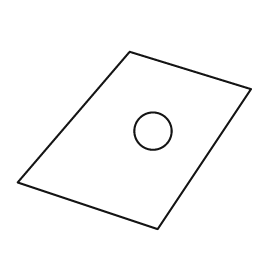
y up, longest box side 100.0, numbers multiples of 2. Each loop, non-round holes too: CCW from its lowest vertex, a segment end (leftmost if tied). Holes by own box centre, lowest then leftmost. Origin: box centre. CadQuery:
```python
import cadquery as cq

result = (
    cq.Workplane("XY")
    .moveTo(10.0, -38.0)
    .lineTo(50.0, 22.0)
    .lineTo(-2.0, 38.0)
    .lineTo(-50.0, -18.0)
    .close()
    .moveTo(8.0, 4.0)
    .circle(8.0)
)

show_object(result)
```